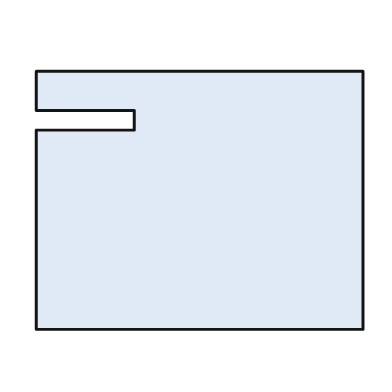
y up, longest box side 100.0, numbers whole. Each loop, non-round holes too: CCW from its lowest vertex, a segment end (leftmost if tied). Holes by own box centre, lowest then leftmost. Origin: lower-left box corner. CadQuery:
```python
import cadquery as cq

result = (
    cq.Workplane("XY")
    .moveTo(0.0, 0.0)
    .lineTo(100.0, 0.0)
    .lineTo(100.0, 79.0)
    .lineTo(0.0, 79.0)
    .lineTo(0.0, 67.0)
    .lineTo(30.0, 67.0)
    .lineTo(30.0, 61.0)
    .lineTo(0.0, 61.0)
    .close()
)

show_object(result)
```